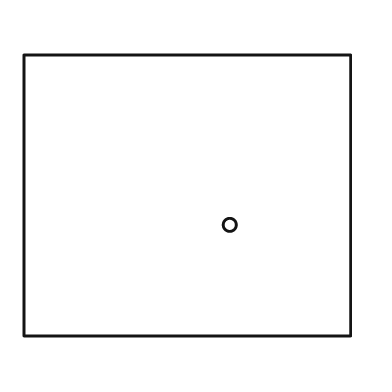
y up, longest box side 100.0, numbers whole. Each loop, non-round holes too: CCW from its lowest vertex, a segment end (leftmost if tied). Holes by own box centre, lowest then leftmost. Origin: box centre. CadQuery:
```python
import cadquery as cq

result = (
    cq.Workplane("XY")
    .moveTo(-50.0, -43.0)
    .lineTo(50.0, -43.0)
    .lineTo(50.0, 43.0)
    .lineTo(-50.0, 43.0)
    .close()
    .moveTo(13.0, -9.0)
    .circle(2.0)
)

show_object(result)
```